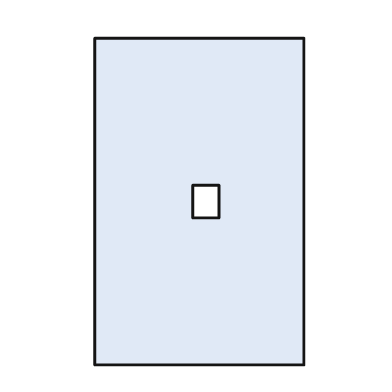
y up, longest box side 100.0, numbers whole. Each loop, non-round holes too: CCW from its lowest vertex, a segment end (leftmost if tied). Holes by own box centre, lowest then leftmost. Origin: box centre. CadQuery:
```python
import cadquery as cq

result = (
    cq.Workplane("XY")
    .moveTo(-32.0, -50.0)
    .lineTo(32.0, -50.0)
    .lineTo(32.0, 50.0)
    .lineTo(-32.0, 50.0)
    .close()
    .moveTo(-2.0, -5.0)
    .lineTo(6.0, -5.0)
    .lineTo(6.0, 5.0)
    .lineTo(-2.0, 5.0)
    .close()
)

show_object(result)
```